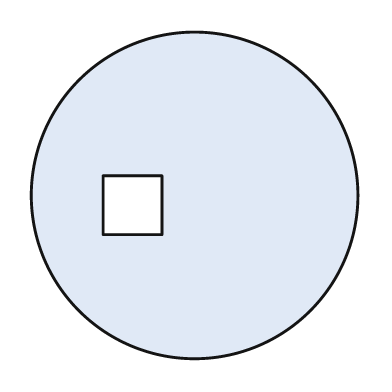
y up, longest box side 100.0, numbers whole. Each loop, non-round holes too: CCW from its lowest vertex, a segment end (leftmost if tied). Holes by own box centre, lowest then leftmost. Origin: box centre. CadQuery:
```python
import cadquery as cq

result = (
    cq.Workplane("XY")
    .moveTo(0.0, 0.0)
    .circle(50.0)
    .moveTo(-28.0, -12.0)
    .lineTo(-10.0, -12.0)
    .lineTo(-10.0, 6.0)
    .lineTo(-28.0, 6.0)
    .close()
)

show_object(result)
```